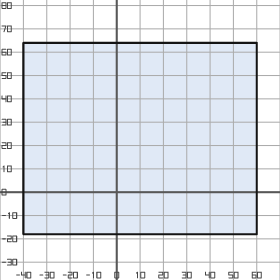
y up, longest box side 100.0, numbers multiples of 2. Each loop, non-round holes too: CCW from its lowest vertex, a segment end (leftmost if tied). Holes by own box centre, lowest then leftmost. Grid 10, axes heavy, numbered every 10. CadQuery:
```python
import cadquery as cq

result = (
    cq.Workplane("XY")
    .moveTo(-40.0, -18.0)
    .lineTo(60.0, -18.0)
    .lineTo(60.0, 64.0)
    .lineTo(-40.0, 64.0)
    .close()
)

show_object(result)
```